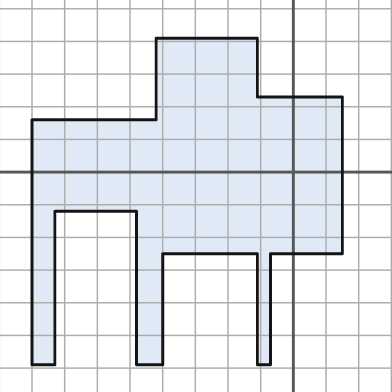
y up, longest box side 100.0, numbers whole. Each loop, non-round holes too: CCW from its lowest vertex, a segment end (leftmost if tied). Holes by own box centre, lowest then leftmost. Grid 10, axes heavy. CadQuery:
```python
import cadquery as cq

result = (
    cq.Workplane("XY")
    .moveTo(-80.0, -59.0)
    .lineTo(-73.0, -59.0)
    .lineTo(-73.0, -12.0)
    .lineTo(-48.0, -12.0)
    .lineTo(-48.0, -59.0)
    .lineTo(-40.0, -59.0)
    .lineTo(-40.0, -25.0)
    .lineTo(-11.0, -25.0)
    .lineTo(-11.0, -59.0)
    .lineTo(-7.0, -59.0)
    .lineTo(-7.0, -25.0)
    .lineTo(15.0, -25.0)
    .lineTo(15.0, 23.0)
    .lineTo(-11.0, 23.0)
    .lineTo(-11.0, 41.0)
    .lineTo(-42.0, 41.0)
    .lineTo(-42.0, 16.0)
    .lineTo(-80.0, 16.0)
    .close()
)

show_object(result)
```